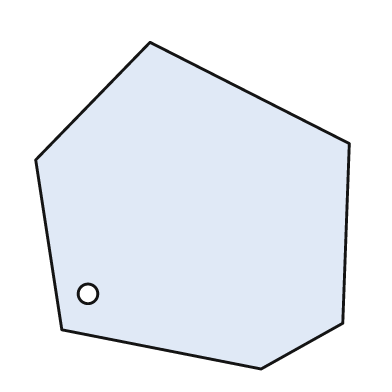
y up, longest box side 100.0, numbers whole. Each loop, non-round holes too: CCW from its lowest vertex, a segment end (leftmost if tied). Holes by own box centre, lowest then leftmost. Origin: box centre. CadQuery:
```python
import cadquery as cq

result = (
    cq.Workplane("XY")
    .moveTo(21.0, -50.0)
    .lineTo(46.0, -36.0)
    .lineTo(48.0, 19.0)
    .lineTo(-13.0, 50.0)
    .lineTo(-48.0, 14.0)
    .lineTo(-40.0, -38.0)
    .close()
    .moveTo(-32.0, -27.0)
    .circle(3.0)
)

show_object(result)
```